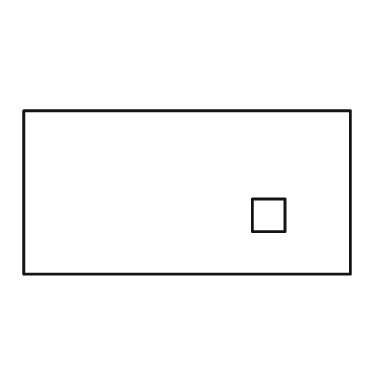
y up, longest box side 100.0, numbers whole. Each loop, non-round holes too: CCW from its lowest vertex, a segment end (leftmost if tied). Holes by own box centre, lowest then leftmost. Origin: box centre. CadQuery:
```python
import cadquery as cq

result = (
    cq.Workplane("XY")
    .moveTo(-50.0, -25.0)
    .lineTo(50.0, -25.0)
    .lineTo(50.0, 25.0)
    .lineTo(-50.0, 25.0)
    .close()
    .moveTo(20.0, -12.0)
    .lineTo(30.0, -12.0)
    .lineTo(30.0, -2.0)
    .lineTo(20.0, -2.0)
    .close()
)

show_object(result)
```